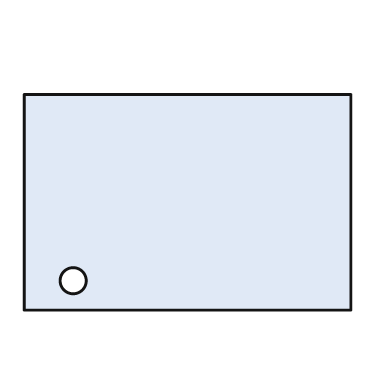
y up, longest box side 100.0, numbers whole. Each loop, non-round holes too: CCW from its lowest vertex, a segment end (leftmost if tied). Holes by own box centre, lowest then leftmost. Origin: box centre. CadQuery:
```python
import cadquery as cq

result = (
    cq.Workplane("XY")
    .moveTo(-50.0, -33.0)
    .lineTo(50.0, -33.0)
    .lineTo(50.0, 33.0)
    .lineTo(-50.0, 33.0)
    .close()
    .moveTo(-35.0, -24.0)
    .circle(4.0)
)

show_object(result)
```